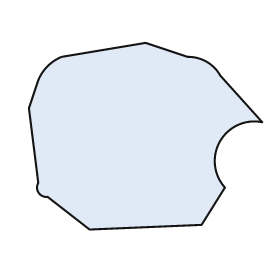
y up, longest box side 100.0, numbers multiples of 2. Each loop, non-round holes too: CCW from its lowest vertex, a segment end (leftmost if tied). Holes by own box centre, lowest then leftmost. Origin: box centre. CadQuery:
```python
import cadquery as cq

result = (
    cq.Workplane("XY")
    .moveTo(-24.0, -40.0)
    .lineTo(24.0, -38.0)
    .lineTo(34.0, -22.0)
    .threePointArc((32.0, -2.0), (50.0, 6.0))
    .lineTo(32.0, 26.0)
    .threePointArc((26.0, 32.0), (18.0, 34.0))
    .lineTo(0.0, 40.0)
    .lineTo(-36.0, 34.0)
    .threePointArc((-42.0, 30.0), (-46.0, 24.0))
    .lineTo(-50.0, 12.0)
    .lineTo(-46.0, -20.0)
    .threePointArc((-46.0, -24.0), (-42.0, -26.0))
    .close()
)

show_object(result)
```